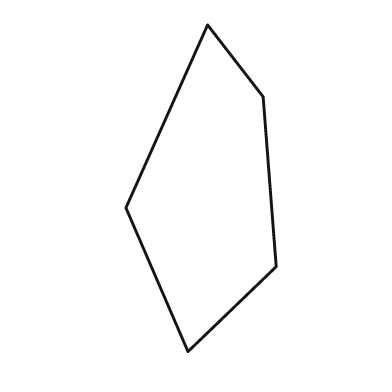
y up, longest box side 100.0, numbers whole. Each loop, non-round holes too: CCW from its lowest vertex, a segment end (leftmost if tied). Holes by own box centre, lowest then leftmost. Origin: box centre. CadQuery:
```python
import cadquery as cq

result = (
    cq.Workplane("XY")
    .moveTo(-4.0, -50.0)
    .lineTo(23.0, -24.0)
    .lineTo(19.0, 28.0)
    .lineTo(2.0, 50.0)
    .lineTo(-23.0, -6.0)
    .close()
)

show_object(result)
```